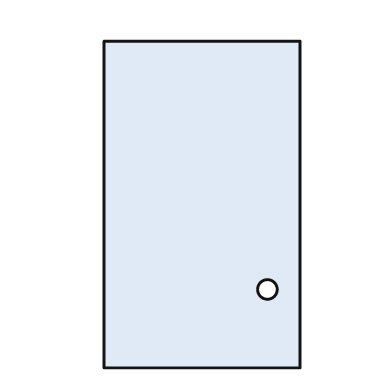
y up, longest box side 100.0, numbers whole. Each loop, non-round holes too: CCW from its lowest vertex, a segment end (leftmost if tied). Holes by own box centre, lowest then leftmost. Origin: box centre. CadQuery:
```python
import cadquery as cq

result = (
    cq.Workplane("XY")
    .moveTo(-30.0, -50.0)
    .lineTo(30.0, -50.0)
    .lineTo(30.0, 50.0)
    .lineTo(-30.0, 50.0)
    .close()
    .moveTo(20.0, -26.0)
    .circle(3.0)
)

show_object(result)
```